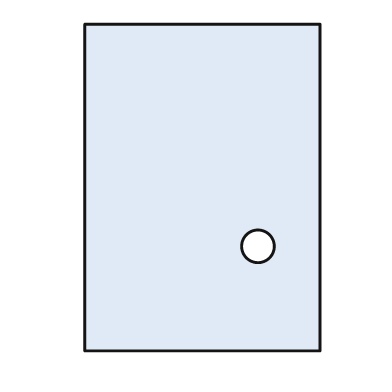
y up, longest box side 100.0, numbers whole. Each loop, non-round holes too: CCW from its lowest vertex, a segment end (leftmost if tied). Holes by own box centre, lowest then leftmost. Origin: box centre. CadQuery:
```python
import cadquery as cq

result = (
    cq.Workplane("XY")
    .moveTo(-36.0, -50.0)
    .lineTo(36.0, -50.0)
    .lineTo(36.0, 50.0)
    .lineTo(-36.0, 50.0)
    .close()
    .moveTo(17.0, -18.0)
    .circle(5.0)
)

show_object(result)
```